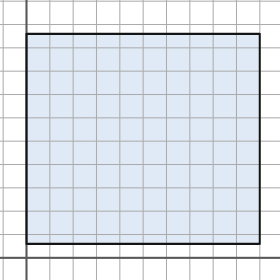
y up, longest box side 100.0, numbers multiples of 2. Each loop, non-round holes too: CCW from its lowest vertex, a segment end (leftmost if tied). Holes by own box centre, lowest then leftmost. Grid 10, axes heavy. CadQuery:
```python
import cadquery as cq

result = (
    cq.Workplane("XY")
    .moveTo(0.0, 6.0)
    .lineTo(100.0, 6.0)
    .lineTo(100.0, 96.0)
    .lineTo(0.0, 96.0)
    .close()
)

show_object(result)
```